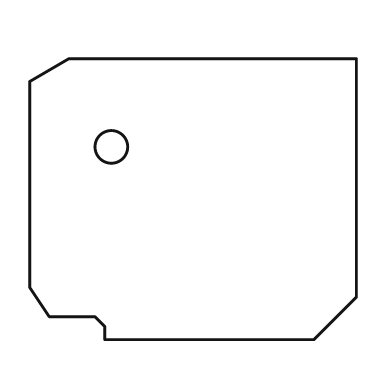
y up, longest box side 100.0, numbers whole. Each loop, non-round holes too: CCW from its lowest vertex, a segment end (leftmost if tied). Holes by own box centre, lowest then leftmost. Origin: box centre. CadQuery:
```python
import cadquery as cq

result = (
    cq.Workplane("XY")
    .moveTo(-27.0, -43.0)
    .lineTo(37.0, -43.0)
    .lineTo(50.0, -30.0)
    .lineTo(50.0, 43.0)
    .lineTo(-38.0, 43.0)
    .lineTo(-50.0, 36.0)
    .lineTo(-50.0, -27.0)
    .lineTo(-44.0, -36.0)
    .lineTo(-30.0, -36.0)
    .lineTo(-27.0, -39.0)
    .close()
    .moveTo(-25.0, 16.0)
    .circle(5.0)
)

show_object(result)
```